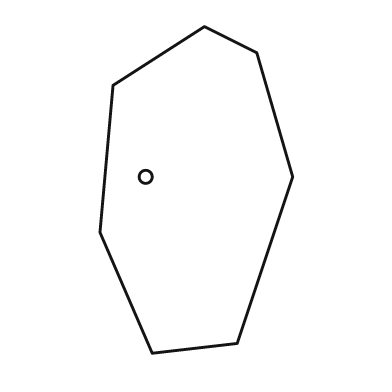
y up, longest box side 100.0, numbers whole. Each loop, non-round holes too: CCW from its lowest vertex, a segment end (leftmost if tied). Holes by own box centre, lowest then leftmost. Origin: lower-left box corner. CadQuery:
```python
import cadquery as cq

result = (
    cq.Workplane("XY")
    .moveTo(16.0, 0.0)
    .lineTo(42.0, 3.0)
    .lineTo(59.0, 54.0)
    .lineTo(48.0, 92.0)
    .lineTo(32.0, 100.0)
    .lineTo(4.0, 82.0)
    .lineTo(0.0, 37.0)
    .close()
    .moveTo(14.0, 54.0)
    .circle(2.0)
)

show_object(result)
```